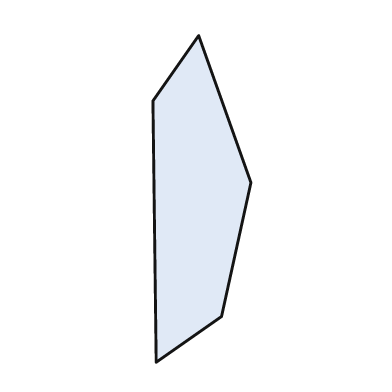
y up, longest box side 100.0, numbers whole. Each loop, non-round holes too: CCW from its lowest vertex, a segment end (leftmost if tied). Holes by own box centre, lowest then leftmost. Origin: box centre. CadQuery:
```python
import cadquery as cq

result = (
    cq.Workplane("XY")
    .moveTo(-14.0, -50.0)
    .lineTo(6.0, -36.0)
    .lineTo(15.0, 5.0)
    .lineTo(-1.0, 50.0)
    .lineTo(-15.0, 30.0)
    .close()
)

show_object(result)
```